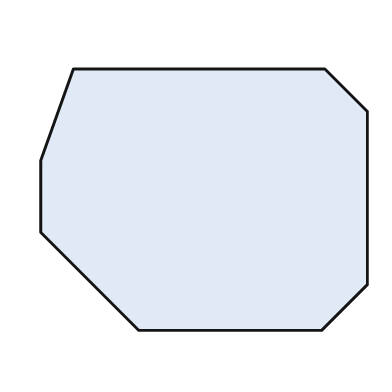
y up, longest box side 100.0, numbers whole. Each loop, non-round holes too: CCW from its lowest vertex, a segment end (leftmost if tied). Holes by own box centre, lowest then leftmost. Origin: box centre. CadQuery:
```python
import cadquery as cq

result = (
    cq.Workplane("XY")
    .moveTo(-20.0, -40.0)
    .lineTo(36.0, -40.0)
    .lineTo(50.0, -26.0)
    .lineTo(50.0, 27.0)
    .lineTo(37.0, 40.0)
    .lineTo(-40.0, 40.0)
    .lineTo(-50.0, 12.0)
    .lineTo(-50.0, -10.0)
    .close()
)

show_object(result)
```